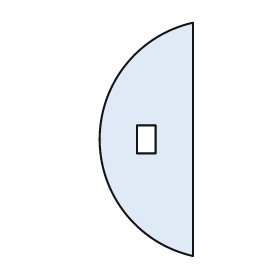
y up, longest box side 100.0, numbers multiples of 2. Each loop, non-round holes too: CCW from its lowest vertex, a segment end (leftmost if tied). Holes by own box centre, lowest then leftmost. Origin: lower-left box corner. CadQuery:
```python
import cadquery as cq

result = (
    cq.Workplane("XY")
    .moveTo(40.0, 0.0)
    .lineTo(40.0, 100.0)
    .threePointArc((0.0, 50.0), (40.0, 0.0))
    .close()
    .moveTo(16.0, 44.0)
    .lineTo(24.0, 44.0)
    .lineTo(24.0, 56.0)
    .lineTo(16.0, 56.0)
    .close()
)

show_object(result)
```